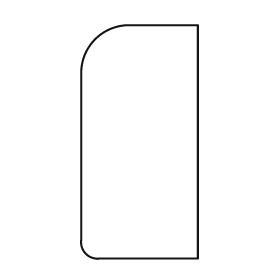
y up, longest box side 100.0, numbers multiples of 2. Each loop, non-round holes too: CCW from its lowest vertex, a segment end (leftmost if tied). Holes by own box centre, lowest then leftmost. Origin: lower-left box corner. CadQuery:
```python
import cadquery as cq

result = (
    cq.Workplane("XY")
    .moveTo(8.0, 0.0)
    .lineTo(50.0, 0.0)
    .lineTo(50.0, 100.0)
    .lineTo(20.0, 100.0)
    .threePointArc((6.0, 94.0), (0.0, 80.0))
    .lineTo(0.0, 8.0)
    .threePointArc((2.0, 2.0), (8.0, 0.0))
    .close()
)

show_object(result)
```